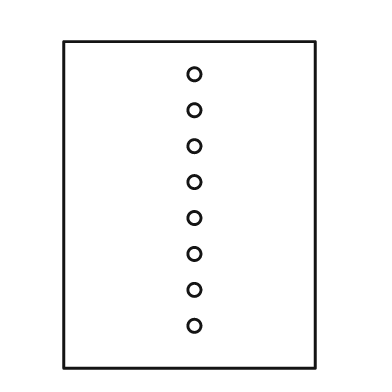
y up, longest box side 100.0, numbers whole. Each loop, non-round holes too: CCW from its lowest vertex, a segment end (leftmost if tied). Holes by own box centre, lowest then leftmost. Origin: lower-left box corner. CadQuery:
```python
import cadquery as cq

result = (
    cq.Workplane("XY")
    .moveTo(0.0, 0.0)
    .lineTo(77.0, 0.0)
    .lineTo(77.0, 100.0)
    .lineTo(0.0, 100.0)
    .close()
    .moveTo(40.0, 13.0)
    .circle(2.0)
    .moveTo(40.0, 24.0)
    .circle(2.0)
    .moveTo(40.0, 35.0)
    .circle(2.0)
    .moveTo(40.0, 46.0)
    .circle(2.0)
    .moveTo(40.0, 57.0)
    .circle(2.0)
    .moveTo(40.0, 68.0)
    .circle(2.0)
    .moveTo(40.0, 79.0)
    .circle(2.0)
    .moveTo(40.0, 90.0)
    .circle(2.0)
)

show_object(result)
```